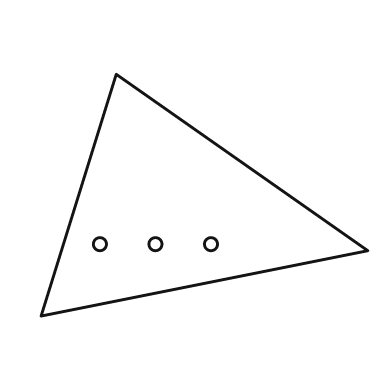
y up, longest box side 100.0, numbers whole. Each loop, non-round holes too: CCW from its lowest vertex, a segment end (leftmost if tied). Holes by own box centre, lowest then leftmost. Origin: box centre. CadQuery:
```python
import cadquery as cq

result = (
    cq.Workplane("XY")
    .moveTo(-50.0, -37.0)
    .lineTo(50.0, -17.0)
    .lineTo(-27.0, 37.0)
    .close()
    .moveTo(-32.0, -15.0)
    .circle(2.0)
    .moveTo(-15.0, -15.0)
    .circle(2.0)
    .moveTo(2.0, -15.0)
    .circle(2.0)
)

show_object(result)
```